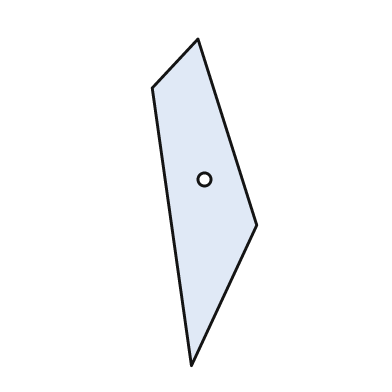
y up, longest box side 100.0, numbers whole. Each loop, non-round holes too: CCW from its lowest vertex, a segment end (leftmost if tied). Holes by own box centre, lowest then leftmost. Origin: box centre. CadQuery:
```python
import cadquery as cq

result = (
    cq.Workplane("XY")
    .moveTo(-4.0, -50.0)
    .lineTo(16.0, -7.0)
    .lineTo(-2.0, 50.0)
    .lineTo(-16.0, 35.0)
    .close()
    .moveTo(0.0, 7.0)
    .circle(2.0)
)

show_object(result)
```